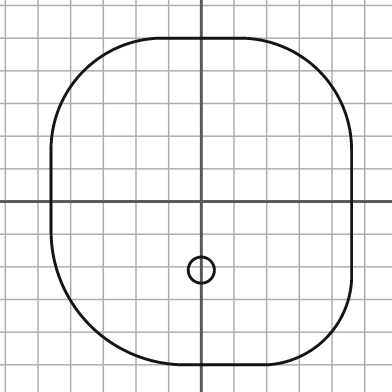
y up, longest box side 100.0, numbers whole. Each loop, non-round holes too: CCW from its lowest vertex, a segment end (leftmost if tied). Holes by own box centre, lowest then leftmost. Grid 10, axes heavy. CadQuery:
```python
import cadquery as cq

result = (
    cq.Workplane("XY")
    .moveTo(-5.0, -50.0)
    .lineTo(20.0, -50.0)
    .threePointArc((38.0, -42.0), (46.0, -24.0))
    .lineTo(46.0, 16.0)
    .threePointArc((36.0, 40.0), (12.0, 50.0))
    .lineTo(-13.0, 50.0)
    .threePointArc((-36.0, 40.0), (-46.0, 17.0))
    .lineTo(-46.0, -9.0)
    .threePointArc((-34.0, -38.0), (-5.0, -50.0))
    .close()
    .moveTo(0.0, -21.0)
    .circle(4.0)
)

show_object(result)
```